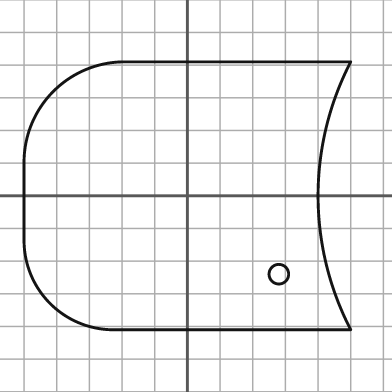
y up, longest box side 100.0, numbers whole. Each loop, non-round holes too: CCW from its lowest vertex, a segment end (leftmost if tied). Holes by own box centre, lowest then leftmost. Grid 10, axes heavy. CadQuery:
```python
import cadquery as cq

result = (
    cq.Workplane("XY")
    .moveTo(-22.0, -41.0)
    .lineTo(50.0, -41.0)
    .threePointArc((40.0, 0.0), (50.0, 41.0))
    .lineTo(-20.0, 41.0)
    .threePointArc((-41.0, 32.0), (-50.0, 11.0))
    .lineTo(-50.0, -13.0)
    .threePointArc((-42.0, -33.0), (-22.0, -41.0))
    .close()
    .moveTo(28.0, -24.0)
    .circle(3.0)
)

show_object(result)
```